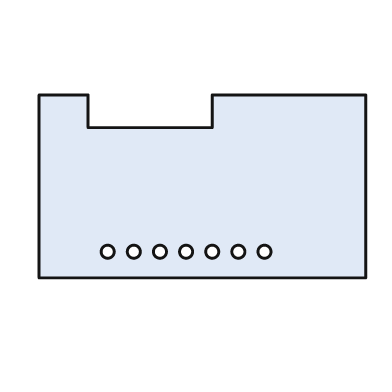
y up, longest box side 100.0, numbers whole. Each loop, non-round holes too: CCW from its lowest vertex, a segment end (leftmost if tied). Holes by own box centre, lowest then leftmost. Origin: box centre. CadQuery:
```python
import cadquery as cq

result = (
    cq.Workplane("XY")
    .moveTo(-50.0, -28.0)
    .lineTo(50.0, -28.0)
    .lineTo(50.0, 28.0)
    .lineTo(3.0, 28.0)
    .lineTo(3.0, 18.0)
    .lineTo(-35.0, 18.0)
    .lineTo(-35.0, 28.0)
    .lineTo(-50.0, 28.0)
    .close()
    .moveTo(-29.0, -20.0)
    .circle(2.0)
    .moveTo(-21.0, -20.0)
    .circle(2.0)
    .moveTo(-13.0, -20.0)
    .circle(2.0)
    .moveTo(-5.0, -20.0)
    .circle(2.0)
    .moveTo(3.0, -20.0)
    .circle(2.0)
    .moveTo(11.0, -20.0)
    .circle(2.0)
    .moveTo(19.0, -20.0)
    .circle(2.0)
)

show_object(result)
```